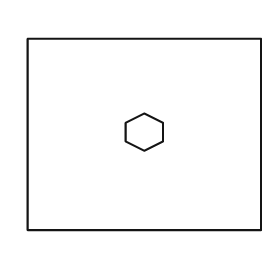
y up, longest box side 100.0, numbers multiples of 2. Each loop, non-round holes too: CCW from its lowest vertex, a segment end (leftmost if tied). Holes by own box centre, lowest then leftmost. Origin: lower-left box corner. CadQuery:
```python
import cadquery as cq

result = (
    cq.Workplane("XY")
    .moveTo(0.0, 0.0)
    .lineTo(100.0, 0.0)
    .lineTo(100.0, 82.0)
    .lineTo(0.0, 82.0)
    .close()
    .moveTo(50.0, 34.0)
    .lineTo(58.0, 38.0)
    .lineTo(58.0, 46.0)
    .lineTo(50.0, 50.0)
    .lineTo(42.0, 46.0)
    .lineTo(42.0, 38.0)
    .close()
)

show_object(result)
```